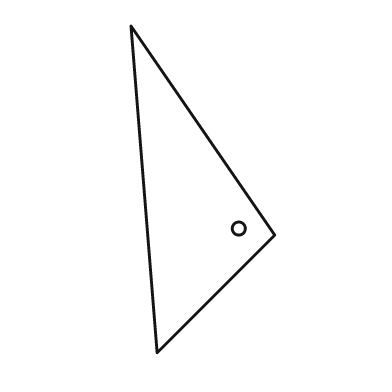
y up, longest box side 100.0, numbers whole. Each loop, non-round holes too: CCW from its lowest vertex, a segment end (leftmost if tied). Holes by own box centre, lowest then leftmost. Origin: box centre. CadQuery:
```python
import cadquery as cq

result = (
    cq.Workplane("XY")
    .moveTo(-14.0, -50.0)
    .lineTo(22.0, -14.0)
    .lineTo(-22.0, 50.0)
    .close()
    .moveTo(11.0, -12.0)
    .circle(2.0)
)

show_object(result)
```